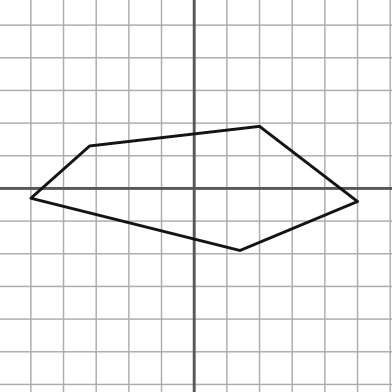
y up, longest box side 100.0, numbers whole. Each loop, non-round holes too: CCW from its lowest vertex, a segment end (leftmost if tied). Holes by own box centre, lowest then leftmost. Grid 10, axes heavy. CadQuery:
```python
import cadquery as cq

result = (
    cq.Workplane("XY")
    .moveTo(14.0, -19.0)
    .lineTo(50.0, -4.0)
    .lineTo(20.0, 19.0)
    .lineTo(-32.0, 13.0)
    .lineTo(-50.0, -3.0)
    .close()
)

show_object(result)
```